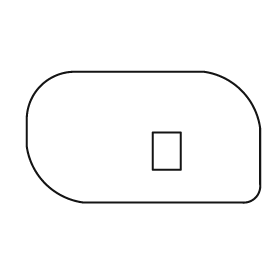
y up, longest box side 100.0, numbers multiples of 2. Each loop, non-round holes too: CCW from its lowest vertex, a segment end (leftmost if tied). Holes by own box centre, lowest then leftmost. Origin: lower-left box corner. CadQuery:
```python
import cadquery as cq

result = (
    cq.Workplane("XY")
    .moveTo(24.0, 0.0)
    .lineTo(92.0, 0.0)
    .threePointArc((98.0, 2.0), (100.0, 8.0))
    .lineTo(100.0, 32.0)
    .threePointArc((92.0, 48.0), (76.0, 56.0))
    .lineTo(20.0, 56.0)
    .threePointArc((6.0, 50.0), (0.0, 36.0))
    .lineTo(0.0, 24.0)
    .threePointArc((8.0, 8.0), (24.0, 0.0))
    .close()
    .moveTo(54.0, 14.0)
    .lineTo(66.0, 14.0)
    .lineTo(66.0, 30.0)
    .lineTo(54.0, 30.0)
    .close()
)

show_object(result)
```